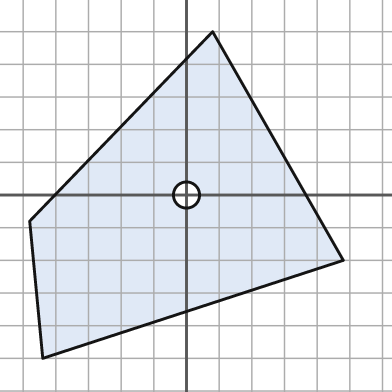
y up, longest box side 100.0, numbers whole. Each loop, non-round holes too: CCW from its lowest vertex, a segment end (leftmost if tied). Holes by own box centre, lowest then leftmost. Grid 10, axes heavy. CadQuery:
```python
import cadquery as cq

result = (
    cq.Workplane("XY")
    .moveTo(-44.0, -50.0)
    .lineTo(48.0, -20.0)
    .lineTo(8.0, 50.0)
    .lineTo(-48.0, -8.0)
    .close()
    .moveTo(0.0, 0.0)
    .circle(4.0)
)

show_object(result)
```